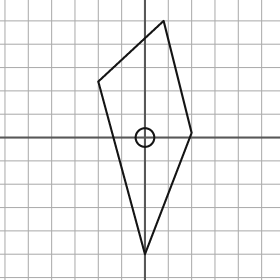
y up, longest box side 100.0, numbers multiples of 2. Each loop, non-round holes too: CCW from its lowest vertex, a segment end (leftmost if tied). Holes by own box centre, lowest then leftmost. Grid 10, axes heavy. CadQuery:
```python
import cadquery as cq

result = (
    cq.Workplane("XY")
    .moveTo(0.0, -50.0)
    .lineTo(20.0, 2.0)
    .lineTo(8.0, 50.0)
    .lineTo(-20.0, 24.0)
    .close()
    .moveTo(0.0, 0.0)
    .circle(4.0)
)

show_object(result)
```